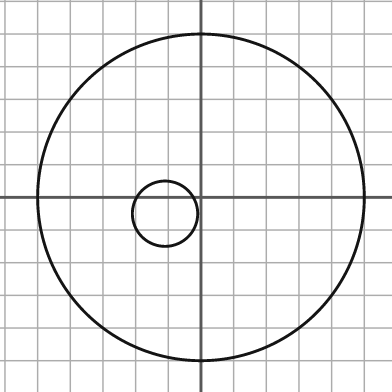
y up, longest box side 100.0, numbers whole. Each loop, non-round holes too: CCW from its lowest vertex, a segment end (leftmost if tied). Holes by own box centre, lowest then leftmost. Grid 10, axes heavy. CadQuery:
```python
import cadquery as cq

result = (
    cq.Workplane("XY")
    .moveTo(0.0, 0.0)
    .circle(50.0)
    .moveTo(-11.0, -5.0)
    .circle(10.0)
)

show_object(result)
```